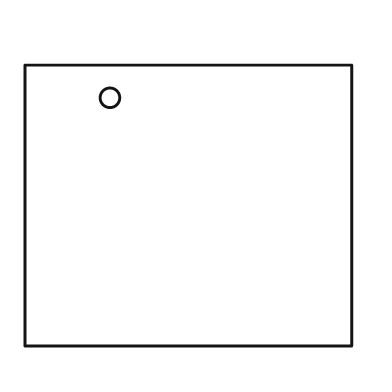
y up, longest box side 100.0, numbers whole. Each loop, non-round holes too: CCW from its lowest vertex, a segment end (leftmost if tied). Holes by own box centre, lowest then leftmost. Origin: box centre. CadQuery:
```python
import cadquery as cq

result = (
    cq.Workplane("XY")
    .moveTo(-50.0, -43.0)
    .lineTo(50.0, -43.0)
    .lineTo(50.0, 43.0)
    .lineTo(-50.0, 43.0)
    .close()
    .moveTo(-24.0, 33.0)
    .circle(3.0)
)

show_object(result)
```